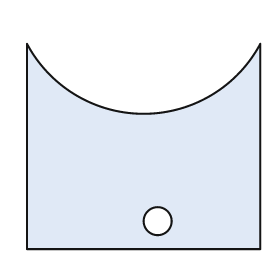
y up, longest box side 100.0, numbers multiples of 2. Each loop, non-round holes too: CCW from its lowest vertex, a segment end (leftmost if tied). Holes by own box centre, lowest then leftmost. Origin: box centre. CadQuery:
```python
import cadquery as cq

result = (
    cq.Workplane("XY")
    .moveTo(-50.0, -44.0)
    .lineTo(50.0, -44.0)
    .lineTo(50.0, 44.0)
    .threePointArc((0.0, 14.0), (-50.0, 44.0))
    .close()
    .moveTo(6.0, -32.0)
    .circle(6.0)
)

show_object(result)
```